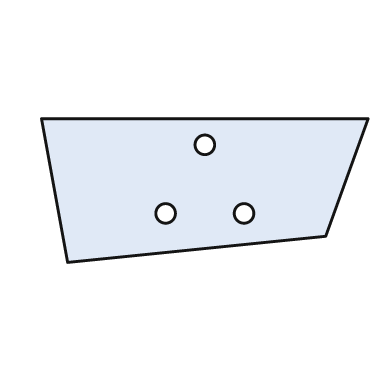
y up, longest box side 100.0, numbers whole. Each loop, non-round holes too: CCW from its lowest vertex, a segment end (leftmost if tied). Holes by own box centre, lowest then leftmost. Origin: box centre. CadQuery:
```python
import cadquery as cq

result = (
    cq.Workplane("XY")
    .moveTo(-42.0, -22.0)
    .lineTo(37.0, -14.0)
    .lineTo(50.0, 22.0)
    .lineTo(-50.0, 22.0)
    .close()
    .moveTo(-12.0, -7.0)
    .circle(3.0)
    .moveTo(12.0, -7.0)
    .circle(3.0)
    .moveTo(0.0, 14.0)
    .circle(3.0)
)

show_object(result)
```